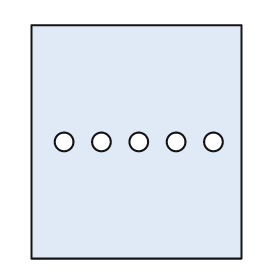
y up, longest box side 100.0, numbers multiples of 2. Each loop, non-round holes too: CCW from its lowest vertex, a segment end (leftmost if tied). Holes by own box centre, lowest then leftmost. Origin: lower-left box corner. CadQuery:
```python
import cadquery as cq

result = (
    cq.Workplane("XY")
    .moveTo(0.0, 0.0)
    .lineTo(90.0, 0.0)
    .lineTo(90.0, 100.0)
    .lineTo(0.0, 100.0)
    .close()
    .moveTo(14.0, 50.0)
    .circle(4.0)
    .moveTo(30.0, 50.0)
    .circle(4.0)
    .moveTo(46.0, 50.0)
    .circle(4.0)
    .moveTo(62.0, 50.0)
    .circle(4.0)
    .moveTo(78.0, 50.0)
    .circle(4.0)
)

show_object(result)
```